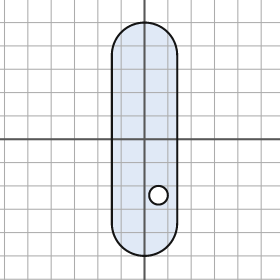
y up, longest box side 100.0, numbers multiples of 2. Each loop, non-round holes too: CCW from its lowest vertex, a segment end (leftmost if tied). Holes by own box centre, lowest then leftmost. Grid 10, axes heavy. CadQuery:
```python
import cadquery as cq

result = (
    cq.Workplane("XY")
    .moveTo(-14.0, -36.0)
    .threePointArc((0.0, -50.0), (14.0, -36.0))
    .lineTo(14.0, 36.0)
    .threePointArc((0.0, 50.0), (-14.0, 36.0))
    .close()
    .moveTo(6.0, -24.0)
    .circle(4.0)
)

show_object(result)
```